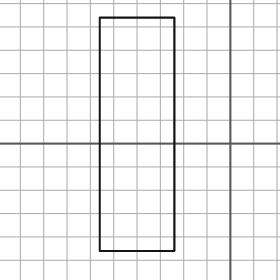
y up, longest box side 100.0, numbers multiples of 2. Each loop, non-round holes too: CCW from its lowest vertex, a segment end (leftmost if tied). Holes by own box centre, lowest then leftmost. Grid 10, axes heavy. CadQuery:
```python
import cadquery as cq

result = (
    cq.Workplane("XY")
    .moveTo(-56.0, -46.0)
    .lineTo(-24.0, -46.0)
    .lineTo(-24.0, 54.0)
    .lineTo(-56.0, 54.0)
    .close()
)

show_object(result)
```